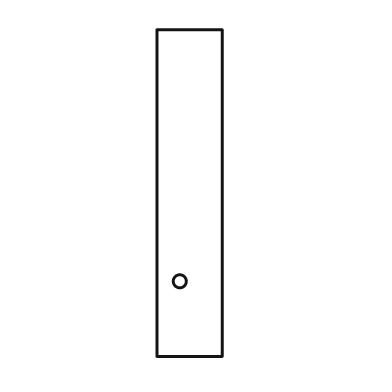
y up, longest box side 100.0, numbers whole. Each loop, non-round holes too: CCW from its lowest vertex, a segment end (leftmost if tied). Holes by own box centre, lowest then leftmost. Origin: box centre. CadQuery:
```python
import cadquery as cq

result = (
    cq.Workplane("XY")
    .moveTo(-10.0, -50.0)
    .lineTo(10.0, -50.0)
    .lineTo(10.0, 50.0)
    .lineTo(-10.0, 50.0)
    .close()
    .moveTo(-3.0, -27.0)
    .circle(2.0)
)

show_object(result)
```